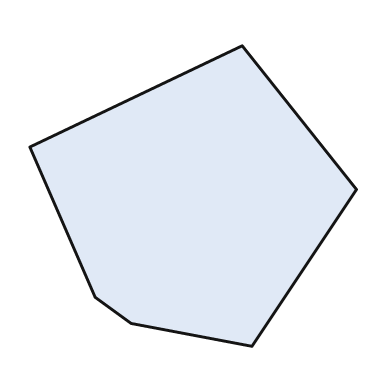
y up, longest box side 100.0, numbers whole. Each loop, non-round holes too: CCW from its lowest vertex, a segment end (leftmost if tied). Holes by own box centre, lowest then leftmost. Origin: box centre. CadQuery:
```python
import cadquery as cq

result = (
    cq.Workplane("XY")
    .moveTo(18.0, -46.0)
    .lineTo(50.0, 2.0)
    .lineTo(15.0, 46.0)
    .lineTo(-50.0, 15.0)
    .lineTo(-30.0, -31.0)
    .lineTo(-19.0, -39.0)
    .close()
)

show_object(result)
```